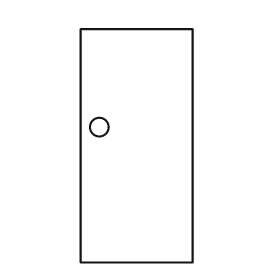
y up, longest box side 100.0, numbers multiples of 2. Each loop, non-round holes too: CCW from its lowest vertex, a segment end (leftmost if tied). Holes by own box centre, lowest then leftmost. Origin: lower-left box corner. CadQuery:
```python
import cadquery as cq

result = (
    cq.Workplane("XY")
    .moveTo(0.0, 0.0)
    .lineTo(48.0, 0.0)
    .lineTo(48.0, 100.0)
    .lineTo(0.0, 100.0)
    .close()
    .moveTo(8.0, 58.0)
    .circle(4.0)
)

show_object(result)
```